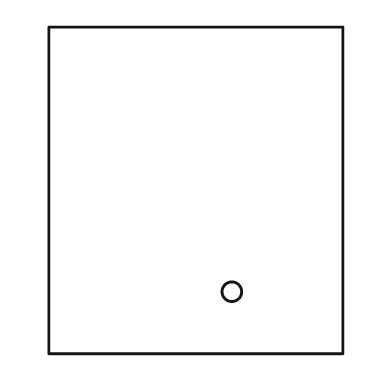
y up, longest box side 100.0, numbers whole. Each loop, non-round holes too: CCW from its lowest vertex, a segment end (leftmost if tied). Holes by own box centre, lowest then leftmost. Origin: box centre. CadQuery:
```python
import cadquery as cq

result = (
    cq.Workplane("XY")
    .moveTo(-45.0, -50.0)
    .lineTo(45.0, -50.0)
    .lineTo(45.0, 50.0)
    .lineTo(-45.0, 50.0)
    .close()
    .moveTo(11.0, -31.0)
    .circle(3.0)
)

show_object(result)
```